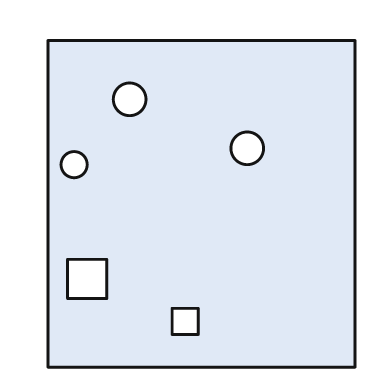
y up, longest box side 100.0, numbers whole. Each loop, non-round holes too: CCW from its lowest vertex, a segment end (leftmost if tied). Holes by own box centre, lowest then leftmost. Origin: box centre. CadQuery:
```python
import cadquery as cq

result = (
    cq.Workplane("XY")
    .moveTo(-47.0, -50.0)
    .lineTo(47.0, -50.0)
    .lineTo(47.0, 50.0)
    .lineTo(-47.0, 50.0)
    .close()
    .moveTo(-9.0, -40.0)
    .lineTo(-1.0, -40.0)
    .lineTo(-1.0, -32.0)
    .lineTo(-9.0, -32.0)
    .close()
    .moveTo(-41.0, -29.0)
    .lineTo(-29.0, -29.0)
    .lineTo(-29.0, -17.0)
    .lineTo(-41.0, -17.0)
    .close()
    .moveTo(-39.0, 12.0)
    .circle(4.0)
    .moveTo(14.0, 17.0)
    .circle(5.0)
    .moveTo(-22.0, 32.0)
    .circle(5.0)
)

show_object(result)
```